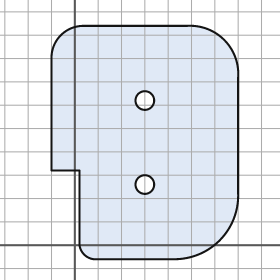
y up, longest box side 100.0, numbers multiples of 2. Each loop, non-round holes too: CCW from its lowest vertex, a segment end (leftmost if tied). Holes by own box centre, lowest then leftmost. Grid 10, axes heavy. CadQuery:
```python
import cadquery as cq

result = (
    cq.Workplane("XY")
    .moveTo(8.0, -6.0)
    .lineTo(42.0, -6.0)
    .threePointArc((62.0, 2.0), (70.0, 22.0))
    .lineTo(70.0, 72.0)
    .threePointArc((64.0, 88.0), (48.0, 94.0))
    .lineTo(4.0, 94.0)
    .threePointArc((-6.0, 90.0), (-10.0, 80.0))
    .lineTo(-10.0, 32.0)
    .lineTo(2.0, 32.0)
    .lineTo(2.0, 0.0)
    .threePointArc((4.0, -4.0), (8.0, -6.0))
    .close()
    .moveTo(30.0, 26.0)
    .circle(4.0)
    .moveTo(30.0, 62.0)
    .circle(4.0)
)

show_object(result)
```